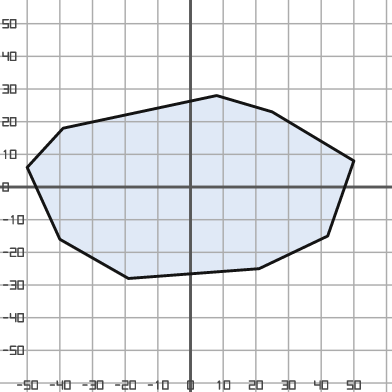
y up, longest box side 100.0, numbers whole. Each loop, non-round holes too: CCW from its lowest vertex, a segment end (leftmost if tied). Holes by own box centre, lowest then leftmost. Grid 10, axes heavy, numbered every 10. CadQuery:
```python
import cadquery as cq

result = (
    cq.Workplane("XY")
    .moveTo(-19.0, -28.0)
    .lineTo(21.0, -25.0)
    .lineTo(42.0, -15.0)
    .lineTo(50.0, 8.0)
    .lineTo(25.0, 23.0)
    .lineTo(8.0, 28.0)
    .lineTo(-39.0, 18.0)
    .lineTo(-50.0, 6.0)
    .lineTo(-40.0, -16.0)
    .close()
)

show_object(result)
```